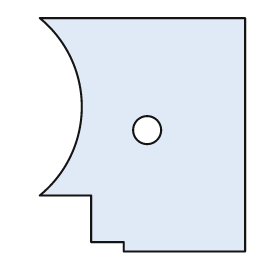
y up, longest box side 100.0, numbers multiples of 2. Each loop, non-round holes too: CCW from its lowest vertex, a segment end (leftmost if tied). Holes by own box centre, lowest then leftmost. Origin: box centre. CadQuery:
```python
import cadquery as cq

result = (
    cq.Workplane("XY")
    .moveTo(-8.0, -50.0)
    .lineTo(44.0, -50.0)
    .lineTo(44.0, 50.0)
    .lineTo(-44.0, 50.0)
    .threePointArc((-26.0, 12.0), (-44.0, -26.0))
    .lineTo(-22.0, -26.0)
    .lineTo(-22.0, -46.0)
    .lineTo(-8.0, -46.0)
    .close()
    .moveTo(2.0, 2.0)
    .circle(6.0)
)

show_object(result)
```